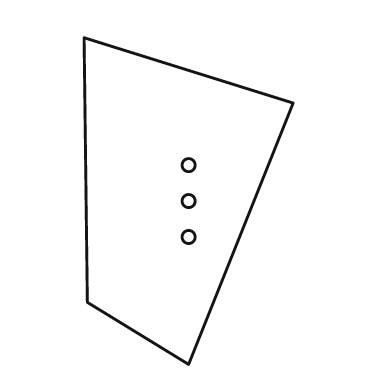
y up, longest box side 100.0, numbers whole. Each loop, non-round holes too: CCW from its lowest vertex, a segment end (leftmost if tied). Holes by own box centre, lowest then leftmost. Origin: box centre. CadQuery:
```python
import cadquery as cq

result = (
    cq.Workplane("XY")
    .moveTo(0.0, -50.0)
    .lineTo(32.0, 30.0)
    .lineTo(-32.0, 50.0)
    .lineTo(-31.0, -31.0)
    .close()
    .moveTo(0.0, -11.0)
    .circle(2.0)
    .moveTo(0.0, 0.0)
    .circle(2.0)
    .moveTo(0.0, 11.0)
    .circle(2.0)
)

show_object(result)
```